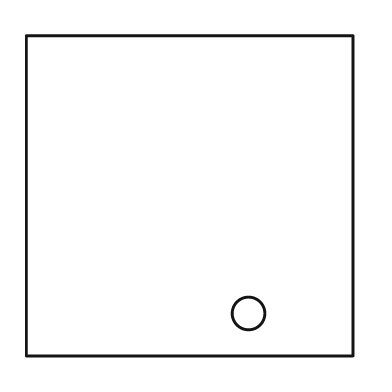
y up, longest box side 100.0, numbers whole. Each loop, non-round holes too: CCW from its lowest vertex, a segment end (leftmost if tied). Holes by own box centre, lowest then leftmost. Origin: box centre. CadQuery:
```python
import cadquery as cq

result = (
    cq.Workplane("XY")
    .moveTo(-50.0, -49.0)
    .lineTo(50.0, -49.0)
    .lineTo(50.0, 49.0)
    .lineTo(-50.0, 49.0)
    .close()
    .moveTo(18.0, -36.0)
    .circle(5.0)
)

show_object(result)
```